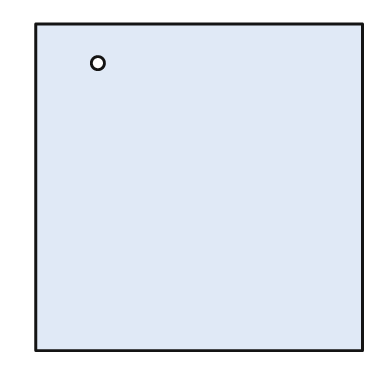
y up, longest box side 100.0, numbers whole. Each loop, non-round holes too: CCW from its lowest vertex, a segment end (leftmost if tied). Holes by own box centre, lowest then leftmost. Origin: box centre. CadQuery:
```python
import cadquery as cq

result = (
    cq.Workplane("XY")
    .moveTo(-50.0, -50.0)
    .lineTo(50.0, -50.0)
    .lineTo(50.0, 50.0)
    .lineTo(-50.0, 50.0)
    .close()
    .moveTo(-31.0, 38.0)
    .circle(2.0)
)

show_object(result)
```